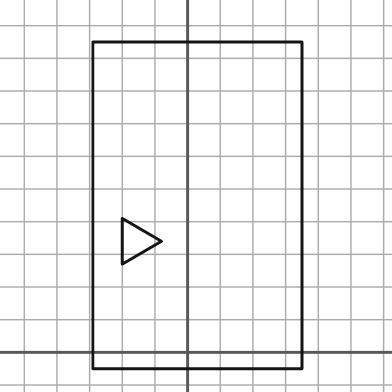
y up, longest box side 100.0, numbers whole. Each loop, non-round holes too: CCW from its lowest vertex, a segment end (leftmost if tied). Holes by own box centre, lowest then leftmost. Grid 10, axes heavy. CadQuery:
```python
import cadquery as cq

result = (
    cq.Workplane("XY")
    .moveTo(-29.0, -5.0)
    .lineTo(35.0, -5.0)
    .lineTo(35.0, 95.0)
    .lineTo(-29.0, 95.0)
    .close()
    .moveTo(-20.0, 27.0)
    .lineTo(-8.0, 34.0)
    .lineTo(-20.0, 41.0)
    .close()
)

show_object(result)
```